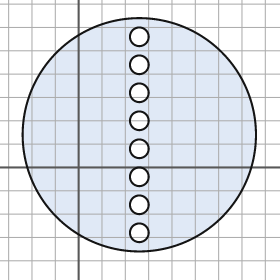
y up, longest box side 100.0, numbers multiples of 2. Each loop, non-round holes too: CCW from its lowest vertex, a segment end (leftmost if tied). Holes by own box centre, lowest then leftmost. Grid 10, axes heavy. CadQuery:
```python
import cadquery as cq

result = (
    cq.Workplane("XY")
    .moveTo(26.0, 14.0)
    .circle(50.0)
    .moveTo(26.0, -28.0)
    .circle(4.0)
    .moveTo(26.0, -16.0)
    .circle(4.0)
    .moveTo(26.0, -4.0)
    .circle(4.0)
    .moveTo(26.0, 8.0)
    .circle(4.0)
    .moveTo(26.0, 20.0)
    .circle(4.0)
    .moveTo(26.0, 32.0)
    .circle(4.0)
    .moveTo(26.0, 44.0)
    .circle(4.0)
    .moveTo(26.0, 56.0)
    .circle(4.0)
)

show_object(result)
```